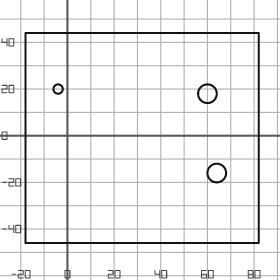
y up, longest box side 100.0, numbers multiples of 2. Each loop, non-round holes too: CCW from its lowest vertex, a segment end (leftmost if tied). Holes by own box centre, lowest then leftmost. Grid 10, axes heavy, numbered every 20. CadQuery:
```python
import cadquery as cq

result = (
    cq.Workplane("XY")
    .moveTo(-18.0, -46.0)
    .lineTo(82.0, -46.0)
    .lineTo(82.0, 44.0)
    .lineTo(-18.0, 44.0)
    .close()
    .moveTo(64.0, -16.0)
    .circle(4.0)
    .moveTo(60.0, 18.0)
    .circle(4.0)
    .moveTo(-4.0, 20.0)
    .circle(2.0)
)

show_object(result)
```